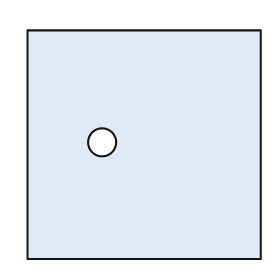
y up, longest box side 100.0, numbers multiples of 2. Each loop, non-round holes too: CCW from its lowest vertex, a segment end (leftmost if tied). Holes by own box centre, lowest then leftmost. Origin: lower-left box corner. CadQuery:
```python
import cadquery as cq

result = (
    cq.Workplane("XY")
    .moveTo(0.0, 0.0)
    .lineTo(100.0, 0.0)
    .lineTo(100.0, 98.0)
    .lineTo(0.0, 98.0)
    .close()
    .moveTo(32.0, 50.0)
    .circle(6.0)
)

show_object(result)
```